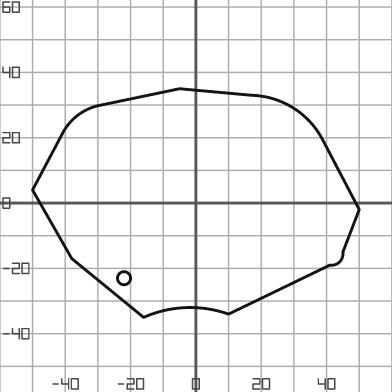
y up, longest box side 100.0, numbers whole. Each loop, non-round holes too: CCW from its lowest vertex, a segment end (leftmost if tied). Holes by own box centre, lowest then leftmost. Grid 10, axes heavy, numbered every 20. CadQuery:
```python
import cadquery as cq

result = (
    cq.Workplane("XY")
    .moveTo(-16.0, -35.0)
    .threePointArc((-3.0, -32.0), (10.0, -34.0))
    .lineTo(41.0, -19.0)
    .threePointArc((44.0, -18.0), (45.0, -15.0))
    .lineTo(50.0, -2.0)
    .lineTo(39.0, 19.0)
    .threePointArc((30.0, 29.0), (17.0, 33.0))
    .lineTo(-5.0, 35.0)
    .lineTo(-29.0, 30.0)
    .threePointArc((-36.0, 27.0), (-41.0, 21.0))
    .lineTo(-50.0, 4.0)
    .lineTo(-38.0, -17.0)
    .close()
    .moveTo(-22.0, -23.0)
    .circle(2.0)
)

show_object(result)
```